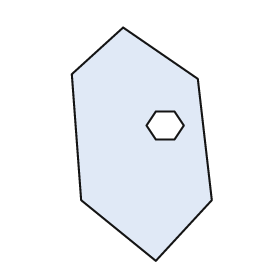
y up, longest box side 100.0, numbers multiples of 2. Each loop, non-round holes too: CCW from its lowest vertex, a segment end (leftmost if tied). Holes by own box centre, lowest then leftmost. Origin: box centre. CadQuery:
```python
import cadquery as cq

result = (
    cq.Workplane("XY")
    .moveTo(6.0, -50.0)
    .lineTo(30.0, -24.0)
    .lineTo(24.0, 28.0)
    .lineTo(-8.0, 50.0)
    .lineTo(-30.0, 30.0)
    .lineTo(-26.0, -24.0)
    .close()
    .moveTo(6.0, 2.0)
    .lineTo(14.0, 2.0)
    .lineTo(18.0, 8.0)
    .lineTo(14.0, 14.0)
    .lineTo(6.0, 14.0)
    .lineTo(2.0, 8.0)
    .close()
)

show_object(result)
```